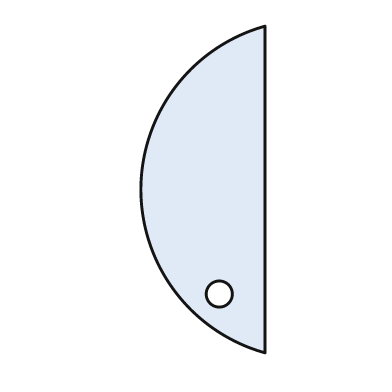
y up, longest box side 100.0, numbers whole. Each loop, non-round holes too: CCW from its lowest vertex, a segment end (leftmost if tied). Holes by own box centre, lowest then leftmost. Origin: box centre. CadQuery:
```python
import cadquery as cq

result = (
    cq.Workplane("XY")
    .moveTo(19.0, -50.0)
    .lineTo(19.0, 50.0)
    .threePointArc((-19.0, 0.0), (19.0, -50.0))
    .close()
    .moveTo(5.0, -32.0)
    .circle(4.0)
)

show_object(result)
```